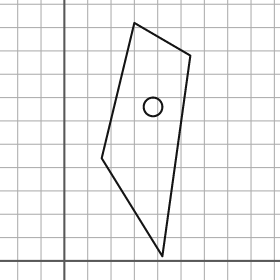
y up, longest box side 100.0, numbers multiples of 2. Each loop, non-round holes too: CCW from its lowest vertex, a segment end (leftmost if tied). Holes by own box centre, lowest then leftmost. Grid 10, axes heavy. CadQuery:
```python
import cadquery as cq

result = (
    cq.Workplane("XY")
    .moveTo(42.0, 2.0)
    .lineTo(54.0, 88.0)
    .lineTo(30.0, 102.0)
    .lineTo(16.0, 44.0)
    .close()
    .moveTo(38.0, 66.0)
    .circle(4.0)
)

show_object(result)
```